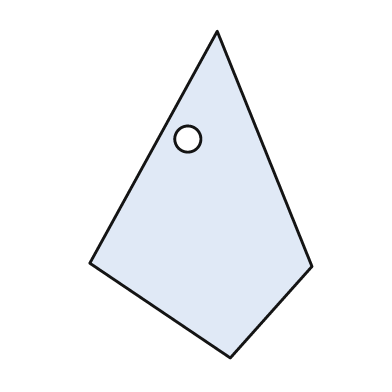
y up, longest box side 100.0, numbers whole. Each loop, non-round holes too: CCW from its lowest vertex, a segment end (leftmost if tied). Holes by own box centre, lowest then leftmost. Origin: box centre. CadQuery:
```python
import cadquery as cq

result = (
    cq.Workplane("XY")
    .moveTo(9.0, -50.0)
    .lineTo(34.0, -22.0)
    .lineTo(5.0, 50.0)
    .lineTo(-34.0, -21.0)
    .close()
    .moveTo(-4.0, 17.0)
    .circle(4.0)
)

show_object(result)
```